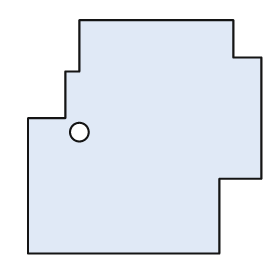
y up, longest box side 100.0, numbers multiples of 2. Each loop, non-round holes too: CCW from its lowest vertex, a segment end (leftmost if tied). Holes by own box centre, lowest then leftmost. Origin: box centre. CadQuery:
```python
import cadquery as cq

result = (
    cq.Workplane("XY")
    .moveTo(-50.0, -50.0)
    .lineTo(32.0, -50.0)
    .lineTo(32.0, -18.0)
    .lineTo(50.0, -18.0)
    .lineTo(50.0, 34.0)
    .lineTo(38.0, 34.0)
    .lineTo(38.0, 50.0)
    .lineTo(-28.0, 50.0)
    .lineTo(-28.0, 28.0)
    .lineTo(-34.0, 28.0)
    .lineTo(-34.0, 8.0)
    .lineTo(-50.0, 8.0)
    .close()
    .moveTo(-28.0, 2.0)
    .circle(4.0)
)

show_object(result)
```